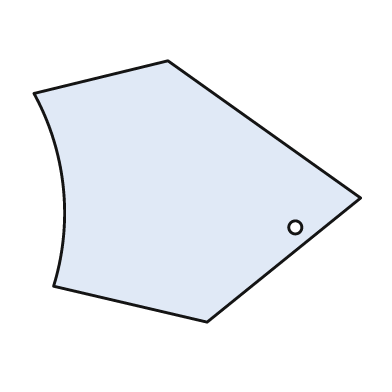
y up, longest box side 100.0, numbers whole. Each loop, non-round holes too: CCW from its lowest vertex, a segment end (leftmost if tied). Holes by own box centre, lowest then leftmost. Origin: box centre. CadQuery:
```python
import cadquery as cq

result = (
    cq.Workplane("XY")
    .moveTo(3.0, -40.0)
    .lineTo(50.0, -2.0)
    .lineTo(-9.0, 40.0)
    .lineTo(-50.0, 30.0)
    .threePointArc((-41.0, 1.0), (-44.0, -29.0))
    .close()
    .moveTo(30.0, -11.0)
    .circle(2.0)
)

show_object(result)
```